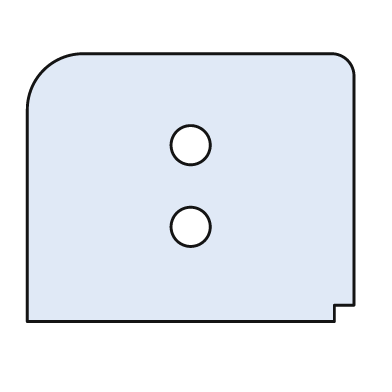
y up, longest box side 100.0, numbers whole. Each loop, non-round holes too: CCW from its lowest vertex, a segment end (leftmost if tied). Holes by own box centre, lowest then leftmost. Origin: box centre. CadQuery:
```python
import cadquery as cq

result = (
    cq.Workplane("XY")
    .moveTo(-50.0, -41.0)
    .lineTo(44.0, -41.0)
    .lineTo(44.0, -36.0)
    .lineTo(50.0, -36.0)
    .lineTo(50.0, 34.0)
    .threePointArc((48.0, 39.0), (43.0, 41.0))
    .lineTo(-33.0, 41.0)
    .threePointArc((-45.0, 36.0), (-50.0, 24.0))
    .close()
    .moveTo(0.0, -12.0)
    .circle(6.0)
    .moveTo(0.0, 13.0)
    .circle(6.0)
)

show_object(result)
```